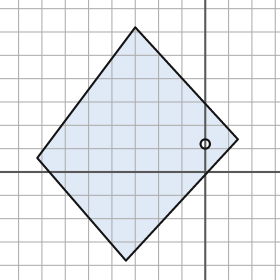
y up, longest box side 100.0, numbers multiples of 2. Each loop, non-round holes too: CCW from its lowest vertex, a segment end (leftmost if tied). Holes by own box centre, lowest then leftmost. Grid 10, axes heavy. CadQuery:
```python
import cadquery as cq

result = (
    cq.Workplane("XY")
    .moveTo(-34.0, -38.0)
    .lineTo(14.0, 14.0)
    .lineTo(-30.0, 62.0)
    .lineTo(-72.0, 6.0)
    .close()
    .moveTo(0.0, 12.0)
    .circle(2.0)
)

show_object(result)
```